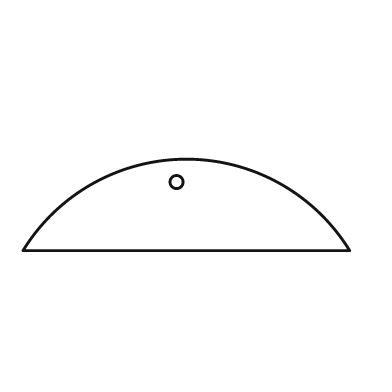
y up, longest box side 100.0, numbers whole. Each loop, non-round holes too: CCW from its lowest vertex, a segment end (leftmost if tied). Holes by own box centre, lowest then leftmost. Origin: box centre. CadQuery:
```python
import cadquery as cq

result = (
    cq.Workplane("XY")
    .moveTo(-50.0, -14.0)
    .lineTo(50.0, -14.0)
    .threePointArc((0.0, 14.0), (-50.0, -14.0))
    .close()
    .moveTo(-3.0, 7.0)
    .circle(2.0)
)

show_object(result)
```